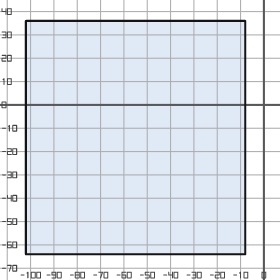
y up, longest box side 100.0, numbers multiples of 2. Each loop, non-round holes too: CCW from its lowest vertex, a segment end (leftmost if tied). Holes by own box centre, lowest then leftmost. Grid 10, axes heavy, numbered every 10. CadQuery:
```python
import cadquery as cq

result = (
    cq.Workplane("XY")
    .moveTo(-102.0, -64.0)
    .lineTo(-8.0, -64.0)
    .lineTo(-8.0, 36.0)
    .lineTo(-102.0, 36.0)
    .close()
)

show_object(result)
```